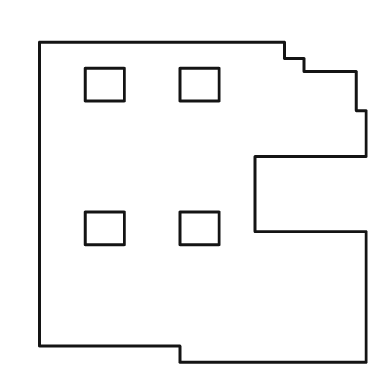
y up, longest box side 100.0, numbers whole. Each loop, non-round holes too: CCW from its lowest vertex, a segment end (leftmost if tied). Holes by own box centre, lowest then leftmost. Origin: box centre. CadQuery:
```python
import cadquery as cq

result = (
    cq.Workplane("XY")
    .moveTo(-7.0, -49.0)
    .lineTo(50.0, -49.0)
    .lineTo(50.0, -9.0)
    .lineTo(16.0, -9.0)
    .lineTo(16.0, 14.0)
    .lineTo(50.0, 14.0)
    .lineTo(50.0, 28.0)
    .lineTo(47.0, 28.0)
    .lineTo(47.0, 40.0)
    .lineTo(31.0, 40.0)
    .lineTo(31.0, 44.0)
    .lineTo(25.0, 44.0)
    .lineTo(25.0, 49.0)
    .lineTo(-50.0, 49.0)
    .lineTo(-50.0, -44.0)
    .lineTo(-7.0, -44.0)
    .close()
    .moveTo(-36.0, -13.0)
    .lineTo(-24.0, -13.0)
    .lineTo(-24.0, -3.0)
    .lineTo(-36.0, -3.0)
    .close()
    .moveTo(-7.0, -13.0)
    .lineTo(5.0, -13.0)
    .lineTo(5.0, -3.0)
    .lineTo(-7.0, -3.0)
    .close()
    .moveTo(-36.0, 31.0)
    .lineTo(-24.0, 31.0)
    .lineTo(-24.0, 41.0)
    .lineTo(-36.0, 41.0)
    .close()
    .moveTo(-7.0, 31.0)
    .lineTo(5.0, 31.0)
    .lineTo(5.0, 41.0)
    .lineTo(-7.0, 41.0)
    .close()
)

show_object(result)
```